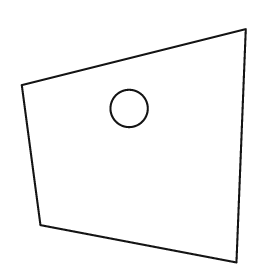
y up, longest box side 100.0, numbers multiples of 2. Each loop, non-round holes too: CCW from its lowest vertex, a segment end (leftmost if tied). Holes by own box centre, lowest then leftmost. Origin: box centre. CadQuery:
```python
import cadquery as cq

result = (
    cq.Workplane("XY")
    .moveTo(44.0, -50.0)
    .lineTo(48.0, 50.0)
    .lineTo(-48.0, 26.0)
    .lineTo(-40.0, -34.0)
    .close()
    .moveTo(-2.0, 16.0)
    .circle(8.0)
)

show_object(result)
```